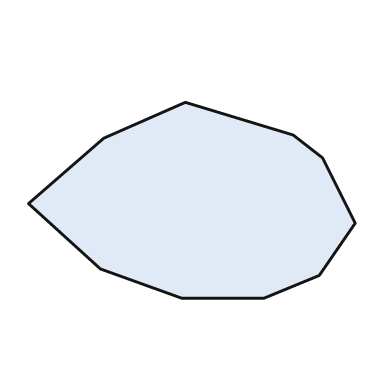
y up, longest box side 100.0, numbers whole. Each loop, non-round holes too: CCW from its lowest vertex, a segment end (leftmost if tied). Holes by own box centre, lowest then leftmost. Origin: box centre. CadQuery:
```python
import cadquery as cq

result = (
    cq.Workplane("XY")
    .moveTo(-3.0, -30.0)
    .lineTo(22.0, -30.0)
    .lineTo(39.0, -23.0)
    .lineTo(50.0, -7.0)
    .lineTo(40.0, 13.0)
    .lineTo(31.0, 20.0)
    .lineTo(-2.0, 30.0)
    .lineTo(-27.0, 19.0)
    .lineTo(-50.0, -1.0)
    .lineTo(-28.0, -21.0)
    .close()
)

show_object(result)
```